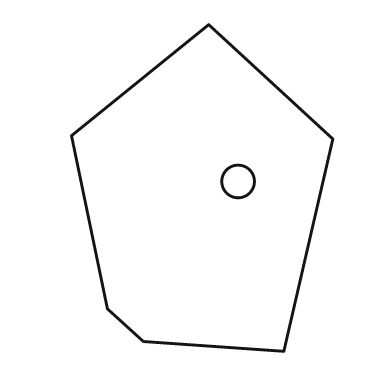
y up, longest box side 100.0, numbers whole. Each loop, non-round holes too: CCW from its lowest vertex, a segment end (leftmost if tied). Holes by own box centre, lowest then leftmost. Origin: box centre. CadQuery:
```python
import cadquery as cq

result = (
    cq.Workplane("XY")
    .moveTo(25.0, -50.0)
    .lineTo(40.0, 15.0)
    .lineTo(2.0, 50.0)
    .lineTo(-40.0, 16.0)
    .lineTo(-29.0, -37.0)
    .lineTo(-18.0, -47.0)
    .close()
    .moveTo(11.0, 2.0)
    .circle(5.0)
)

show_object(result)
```